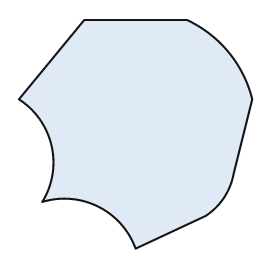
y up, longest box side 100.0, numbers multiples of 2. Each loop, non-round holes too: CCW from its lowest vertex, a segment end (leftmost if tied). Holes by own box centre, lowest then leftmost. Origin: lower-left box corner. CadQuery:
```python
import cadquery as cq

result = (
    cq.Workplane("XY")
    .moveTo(50.0, 0.0)
    .lineTo(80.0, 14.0)
    .threePointArc((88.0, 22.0), (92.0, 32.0))
    .lineTo(100.0, 64.0)
    .threePointArc((90.0, 84.0), (72.0, 98.0))
    .lineTo(28.0, 98.0)
    .lineTo(0.0, 64.0)
    .threePointArc((14.0, 44.0), (10.0, 20.0))
    .threePointArc((34.0, 18.0), (50.0, 0.0))
    .close()
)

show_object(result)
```